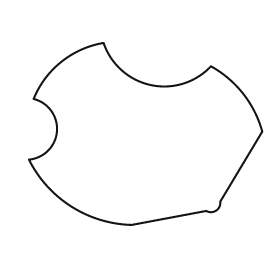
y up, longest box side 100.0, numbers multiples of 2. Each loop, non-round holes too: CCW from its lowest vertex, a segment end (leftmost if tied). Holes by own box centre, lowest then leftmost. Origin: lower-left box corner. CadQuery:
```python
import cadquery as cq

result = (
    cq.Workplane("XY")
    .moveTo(44.0, 0.0)
    .lineTo(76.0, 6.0)
    .threePointArc((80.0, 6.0), (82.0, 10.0))
    .lineTo(100.0, 40.0)
    .threePointArc((92.0, 56.0), (78.0, 68.0))
    .threePointArc((52.0, 60.0), (32.0, 78.0))
    .threePointArc((14.0, 70.0), (2.0, 54.0))
    .threePointArc((12.0, 40.0), (0.0, 28.0))
    .threePointArc((18.0, 8.0), (44.0, 0.0))
    .close()
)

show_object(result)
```